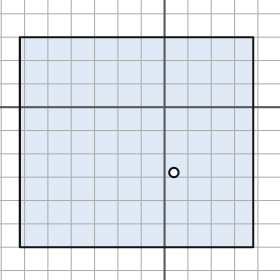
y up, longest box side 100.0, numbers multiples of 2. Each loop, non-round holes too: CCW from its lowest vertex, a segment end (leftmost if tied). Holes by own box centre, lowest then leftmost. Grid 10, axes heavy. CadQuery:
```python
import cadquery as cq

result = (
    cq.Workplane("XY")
    .moveTo(-62.0, -60.0)
    .lineTo(38.0, -60.0)
    .lineTo(38.0, 30.0)
    .lineTo(-62.0, 30.0)
    .close()
    .moveTo(4.0, -28.0)
    .circle(2.0)
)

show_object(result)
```